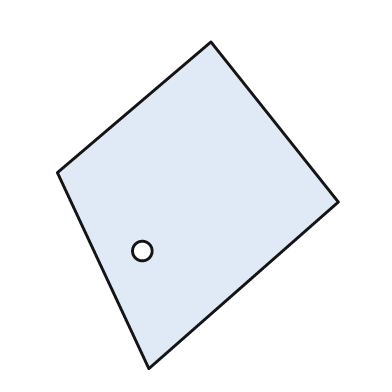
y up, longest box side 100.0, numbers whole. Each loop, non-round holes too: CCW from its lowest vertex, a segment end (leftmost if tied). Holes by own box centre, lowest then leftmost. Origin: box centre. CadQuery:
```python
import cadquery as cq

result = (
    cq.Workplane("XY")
    .moveTo(-15.0, -50.0)
    .lineTo(43.0, 1.0)
    .lineTo(4.0, 50.0)
    .lineTo(-43.0, 10.0)
    .close()
    .moveTo(-17.0, -14.0)
    .circle(3.0)
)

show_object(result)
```